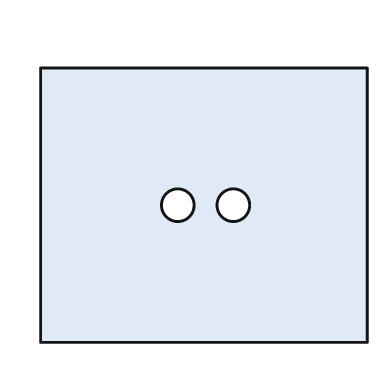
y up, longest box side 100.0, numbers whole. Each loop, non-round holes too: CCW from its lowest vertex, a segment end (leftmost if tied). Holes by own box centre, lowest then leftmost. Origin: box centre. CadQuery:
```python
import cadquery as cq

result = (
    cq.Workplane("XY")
    .moveTo(-50.0, -42.0)
    .lineTo(50.0, -42.0)
    .lineTo(50.0, 42.0)
    .lineTo(-50.0, 42.0)
    .close()
    .moveTo(-8.0, 0.0)
    .circle(5.0)
    .moveTo(9.0, 0.0)
    .circle(5.0)
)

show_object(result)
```